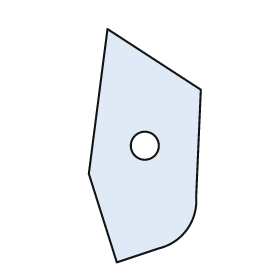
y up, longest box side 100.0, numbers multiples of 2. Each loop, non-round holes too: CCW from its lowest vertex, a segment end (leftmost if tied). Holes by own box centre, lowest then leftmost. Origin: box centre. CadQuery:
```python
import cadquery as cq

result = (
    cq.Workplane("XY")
    .moveTo(-12.0, -50.0)
    .lineTo(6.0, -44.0)
    .threePointArc((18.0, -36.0), (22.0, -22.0))
    .lineTo(24.0, 24.0)
    .lineTo(-16.0, 50.0)
    .lineTo(-24.0, -12.0)
    .close()
    .moveTo(0.0, 0.0)
    .circle(6.0)
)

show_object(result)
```